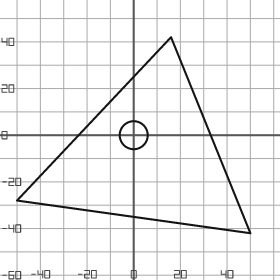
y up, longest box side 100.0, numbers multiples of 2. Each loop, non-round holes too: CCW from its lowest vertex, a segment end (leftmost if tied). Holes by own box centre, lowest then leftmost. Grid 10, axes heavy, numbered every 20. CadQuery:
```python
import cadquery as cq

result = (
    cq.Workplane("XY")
    .moveTo(50.0, -42.0)
    .lineTo(16.0, 42.0)
    .lineTo(-50.0, -28.0)
    .close()
    .moveTo(0.0, 0.0)
    .circle(6.0)
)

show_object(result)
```